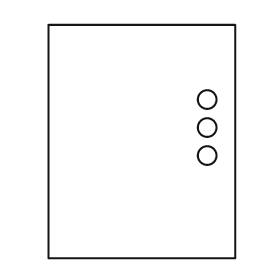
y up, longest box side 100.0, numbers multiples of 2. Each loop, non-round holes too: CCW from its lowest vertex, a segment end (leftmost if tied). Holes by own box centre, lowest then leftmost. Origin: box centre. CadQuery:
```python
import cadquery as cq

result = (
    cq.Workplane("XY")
    .moveTo(-40.0, -50.0)
    .lineTo(40.0, -50.0)
    .lineTo(40.0, 50.0)
    .lineTo(-40.0, 50.0)
    .close()
    .moveTo(28.0, -6.0)
    .circle(4.0)
    .moveTo(28.0, 6.0)
    .circle(4.0)
    .moveTo(28.0, 18.0)
    .circle(4.0)
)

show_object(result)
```